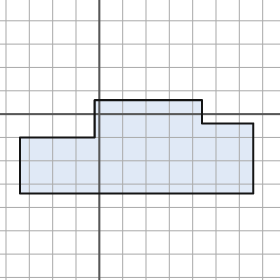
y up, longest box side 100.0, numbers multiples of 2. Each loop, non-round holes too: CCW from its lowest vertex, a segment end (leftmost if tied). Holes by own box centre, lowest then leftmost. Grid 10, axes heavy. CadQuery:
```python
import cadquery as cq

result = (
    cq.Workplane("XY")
    .moveTo(-34.0, -34.0)
    .lineTo(66.0, -34.0)
    .lineTo(66.0, -4.0)
    .lineTo(44.0, -4.0)
    .lineTo(44.0, 6.0)
    .lineTo(-2.0, 6.0)
    .lineTo(-2.0, -10.0)
    .lineTo(-34.0, -10.0)
    .close()
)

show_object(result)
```